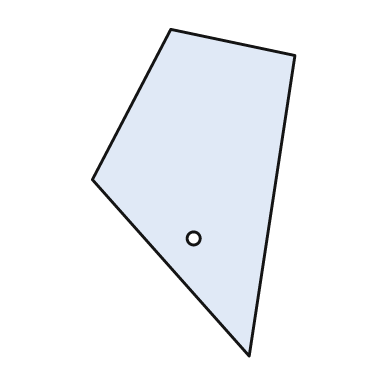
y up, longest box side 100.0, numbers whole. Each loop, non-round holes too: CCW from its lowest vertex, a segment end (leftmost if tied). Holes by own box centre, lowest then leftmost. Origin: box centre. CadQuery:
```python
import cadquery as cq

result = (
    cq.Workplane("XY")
    .moveTo(17.0, -50.0)
    .lineTo(31.0, 42.0)
    .lineTo(-7.0, 50.0)
    .lineTo(-31.0, 4.0)
    .close()
    .moveTo(0.0, -14.0)
    .circle(2.0)
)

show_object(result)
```